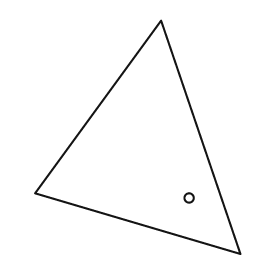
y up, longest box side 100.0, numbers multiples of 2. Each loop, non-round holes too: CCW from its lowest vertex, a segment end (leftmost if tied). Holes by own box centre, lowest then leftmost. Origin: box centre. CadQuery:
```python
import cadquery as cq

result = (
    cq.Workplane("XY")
    .moveTo(44.0, -50.0)
    .lineTo(10.0, 50.0)
    .lineTo(-44.0, -24.0)
    .close()
    .moveTo(22.0, -26.0)
    .circle(2.0)
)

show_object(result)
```